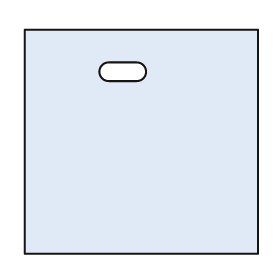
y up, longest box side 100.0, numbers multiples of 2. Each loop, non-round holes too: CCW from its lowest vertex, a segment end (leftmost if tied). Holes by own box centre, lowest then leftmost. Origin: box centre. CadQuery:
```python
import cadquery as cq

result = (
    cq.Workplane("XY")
    .moveTo(-50.0, -48.0)
    .lineTo(50.0, -48.0)
    .lineTo(50.0, 48.0)
    .lineTo(-50.0, 48.0)
    .close()
    .moveTo(-14.0, 26.0)
    .lineTo(-2.0, 26.0)
    .threePointArc((2.0, 30.0), (-2.0, 34.0))
    .lineTo(-14.0, 34.0)
    .threePointArc((-18.0, 30.0), (-14.0, 26.0))
    .close()
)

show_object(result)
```